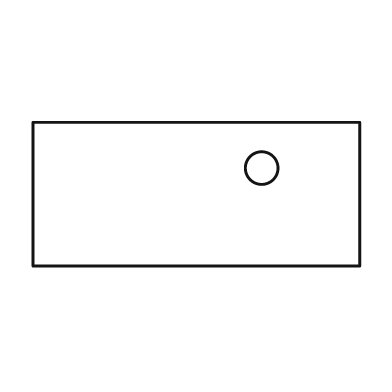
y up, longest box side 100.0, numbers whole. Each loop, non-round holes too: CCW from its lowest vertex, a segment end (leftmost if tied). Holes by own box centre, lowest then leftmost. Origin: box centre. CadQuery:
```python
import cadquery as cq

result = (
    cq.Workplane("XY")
    .moveTo(-50.0, -22.0)
    .lineTo(50.0, -22.0)
    .lineTo(50.0, 22.0)
    .lineTo(-50.0, 22.0)
    .close()
    .moveTo(20.0, 8.0)
    .circle(5.0)
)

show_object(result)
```